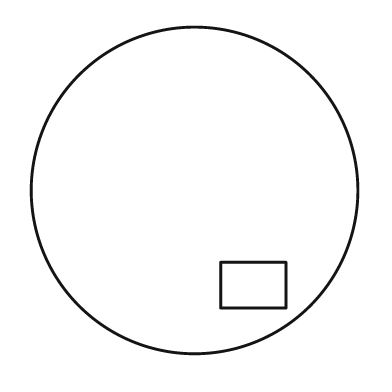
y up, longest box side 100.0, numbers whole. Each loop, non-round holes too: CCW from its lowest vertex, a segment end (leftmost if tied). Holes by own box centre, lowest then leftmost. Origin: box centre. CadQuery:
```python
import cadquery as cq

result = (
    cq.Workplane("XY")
    .moveTo(0.0, 0.0)
    .circle(50.0)
    .moveTo(8.0, -36.0)
    .lineTo(28.0, -36.0)
    .lineTo(28.0, -22.0)
    .lineTo(8.0, -22.0)
    .close()
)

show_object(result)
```